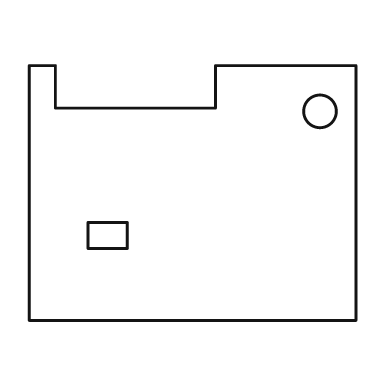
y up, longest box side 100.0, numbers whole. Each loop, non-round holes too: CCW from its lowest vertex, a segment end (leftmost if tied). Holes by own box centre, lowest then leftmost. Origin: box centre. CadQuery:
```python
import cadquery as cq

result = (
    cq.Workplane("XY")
    .moveTo(-50.0, -39.0)
    .lineTo(50.0, -39.0)
    .lineTo(50.0, 39.0)
    .lineTo(7.0, 39.0)
    .lineTo(7.0, 26.0)
    .lineTo(-42.0, 26.0)
    .lineTo(-42.0, 39.0)
    .lineTo(-50.0, 39.0)
    .close()
    .moveTo(-32.0, -17.0)
    .lineTo(-20.0, -17.0)
    .lineTo(-20.0, -9.0)
    .lineTo(-32.0, -9.0)
    .close()
    .moveTo(39.0, 25.0)
    .circle(5.0)
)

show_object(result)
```